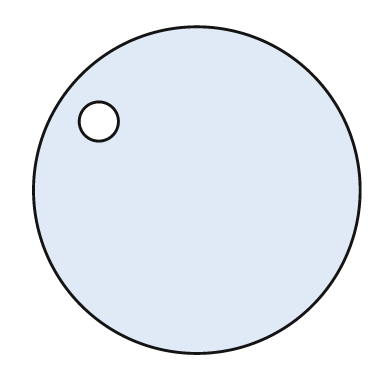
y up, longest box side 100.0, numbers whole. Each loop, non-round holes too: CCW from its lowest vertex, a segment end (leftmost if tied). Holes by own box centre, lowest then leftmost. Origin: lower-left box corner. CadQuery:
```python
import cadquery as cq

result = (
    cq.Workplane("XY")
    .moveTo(50.0, 50.0)
    .circle(50.0)
    .moveTo(20.0, 71.0)
    .circle(6.0)
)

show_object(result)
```